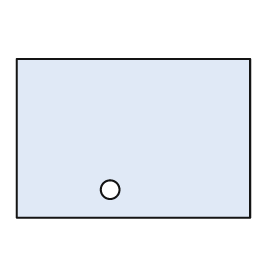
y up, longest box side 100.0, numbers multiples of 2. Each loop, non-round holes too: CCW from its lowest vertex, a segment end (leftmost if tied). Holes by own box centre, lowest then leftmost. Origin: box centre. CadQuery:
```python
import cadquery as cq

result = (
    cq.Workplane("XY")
    .moveTo(-50.0, -34.0)
    .lineTo(50.0, -34.0)
    .lineTo(50.0, 34.0)
    .lineTo(-50.0, 34.0)
    .close()
    .moveTo(-10.0, -22.0)
    .circle(4.0)
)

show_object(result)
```